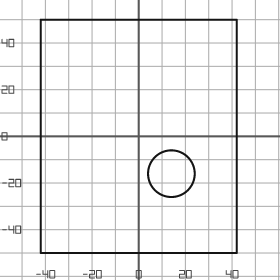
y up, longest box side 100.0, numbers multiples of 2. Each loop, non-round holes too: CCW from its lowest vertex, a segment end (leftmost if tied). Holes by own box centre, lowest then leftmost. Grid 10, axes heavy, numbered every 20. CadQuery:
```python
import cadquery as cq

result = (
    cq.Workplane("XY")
    .moveTo(-42.0, -50.0)
    .lineTo(42.0, -50.0)
    .lineTo(42.0, 50.0)
    .lineTo(-42.0, 50.0)
    .close()
    .moveTo(14.0, -16.0)
    .circle(10.0)
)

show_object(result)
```